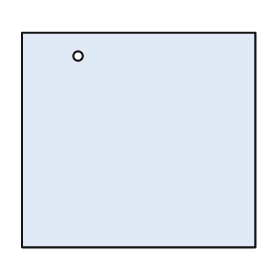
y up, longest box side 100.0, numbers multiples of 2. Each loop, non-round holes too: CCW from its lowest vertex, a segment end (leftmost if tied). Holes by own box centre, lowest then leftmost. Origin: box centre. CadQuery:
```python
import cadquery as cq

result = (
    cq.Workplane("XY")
    .moveTo(-50.0, -46.0)
    .lineTo(50.0, -46.0)
    .lineTo(50.0, 46.0)
    .lineTo(-50.0, 46.0)
    .close()
    .moveTo(-26.0, 36.0)
    .circle(2.0)
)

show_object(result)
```